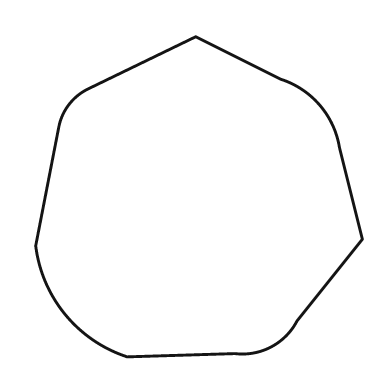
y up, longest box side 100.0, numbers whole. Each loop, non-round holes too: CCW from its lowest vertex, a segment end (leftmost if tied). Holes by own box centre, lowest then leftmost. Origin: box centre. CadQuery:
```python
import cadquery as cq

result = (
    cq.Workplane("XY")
    .moveTo(-22.0, -49.0)
    .lineTo(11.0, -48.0)
    .threePointArc((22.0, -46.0), (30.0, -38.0))
    .lineTo(50.0, -13.0)
    .lineTo(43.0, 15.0)
    .threePointArc((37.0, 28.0), (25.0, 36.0))
    .lineTo(-1.0, 49.0)
    .lineTo(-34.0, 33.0)
    .threePointArc((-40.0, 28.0), (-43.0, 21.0))
    .lineTo(-50.0, -15.0)
    .threePointArc((-41.0, -36.0), (-22.0, -49.0))
    .close()
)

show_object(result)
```